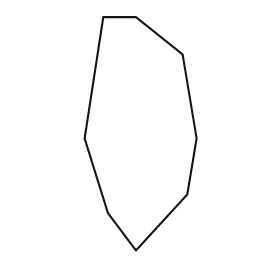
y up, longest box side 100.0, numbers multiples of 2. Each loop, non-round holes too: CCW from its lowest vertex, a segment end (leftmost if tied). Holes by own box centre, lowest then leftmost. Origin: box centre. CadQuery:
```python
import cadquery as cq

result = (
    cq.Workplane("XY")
    .moveTo(-2.0, -50.0)
    .lineTo(20.0, -26.0)
    .lineTo(24.0, -2.0)
    .lineTo(18.0, 34.0)
    .lineTo(-2.0, 50.0)
    .lineTo(-16.0, 50.0)
    .lineTo(-24.0, -2.0)
    .lineTo(-14.0, -34.0)
    .close()
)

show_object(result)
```